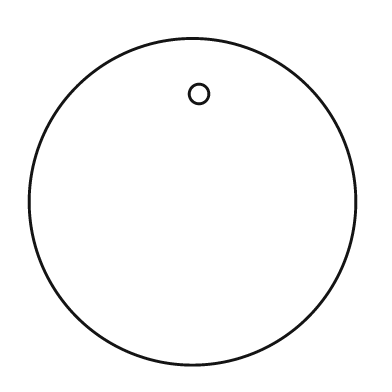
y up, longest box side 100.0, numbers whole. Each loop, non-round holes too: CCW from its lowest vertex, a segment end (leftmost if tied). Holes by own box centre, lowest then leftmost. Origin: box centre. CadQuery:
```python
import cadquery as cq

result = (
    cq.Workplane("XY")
    .moveTo(0.0, 0.0)
    .circle(50.0)
    .moveTo(2.0, 33.0)
    .circle(3.0)
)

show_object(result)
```